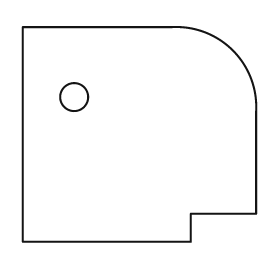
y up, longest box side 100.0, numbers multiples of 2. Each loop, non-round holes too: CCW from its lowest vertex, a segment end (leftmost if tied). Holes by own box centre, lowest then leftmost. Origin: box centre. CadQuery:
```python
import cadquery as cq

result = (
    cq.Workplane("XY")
    .moveTo(-50.0, -46.0)
    .lineTo(22.0, -46.0)
    .lineTo(22.0, -34.0)
    .lineTo(50.0, -34.0)
    .lineTo(50.0, 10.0)
    .threePointArc((40.0, 36.0), (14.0, 46.0))
    .lineTo(-50.0, 46.0)
    .close()
    .moveTo(-28.0, 16.0)
    .circle(6.0)
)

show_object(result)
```